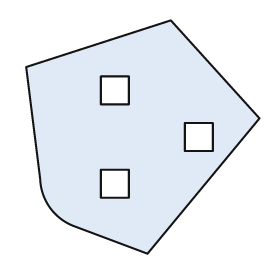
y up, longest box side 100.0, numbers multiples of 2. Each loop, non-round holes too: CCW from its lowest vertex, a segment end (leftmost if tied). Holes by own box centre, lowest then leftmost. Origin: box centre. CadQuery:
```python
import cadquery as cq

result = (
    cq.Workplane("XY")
    .moveTo(2.0, -50.0)
    .lineTo(50.0, 8.0)
    .lineTo(12.0, 50.0)
    .lineTo(-50.0, 30.0)
    .lineTo(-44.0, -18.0)
    .threePointArc((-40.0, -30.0), (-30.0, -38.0))
    .close()
    .moveTo(-18.0, -26.0)
    .lineTo(-6.0, -26.0)
    .lineTo(-6.0, -14.0)
    .lineTo(-18.0, -14.0)
    .close()
    .moveTo(18.0, -6.0)
    .lineTo(30.0, -6.0)
    .lineTo(30.0, 6.0)
    .lineTo(18.0, 6.0)
    .close()
    .moveTo(-18.0, 14.0)
    .lineTo(-6.0, 14.0)
    .lineTo(-6.0, 26.0)
    .lineTo(-18.0, 26.0)
    .close()
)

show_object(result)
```